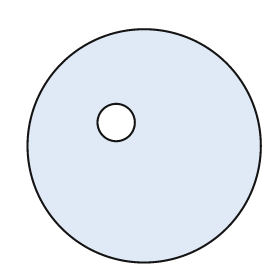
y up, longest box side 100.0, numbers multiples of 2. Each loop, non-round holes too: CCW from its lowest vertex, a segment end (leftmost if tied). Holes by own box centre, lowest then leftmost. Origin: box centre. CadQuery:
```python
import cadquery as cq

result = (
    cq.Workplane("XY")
    .moveTo(0.0, 0.0)
    .circle(50.0)
    .moveTo(-12.0, 10.0)
    .circle(8.0)
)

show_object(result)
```